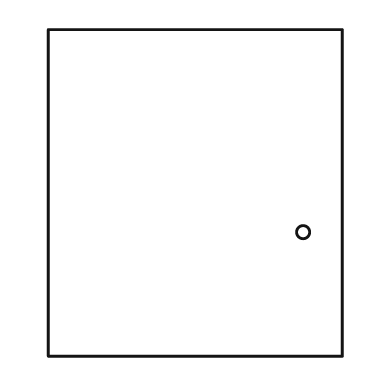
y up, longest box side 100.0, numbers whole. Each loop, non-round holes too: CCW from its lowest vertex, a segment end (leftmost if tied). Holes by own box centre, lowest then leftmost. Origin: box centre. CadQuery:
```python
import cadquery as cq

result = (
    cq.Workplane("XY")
    .moveTo(-45.0, -50.0)
    .lineTo(45.0, -50.0)
    .lineTo(45.0, 50.0)
    .lineTo(-45.0, 50.0)
    .close()
    .moveTo(33.0, -12.0)
    .circle(2.0)
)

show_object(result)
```